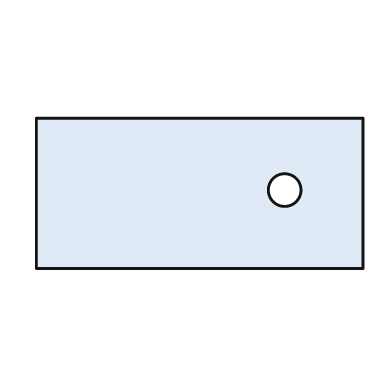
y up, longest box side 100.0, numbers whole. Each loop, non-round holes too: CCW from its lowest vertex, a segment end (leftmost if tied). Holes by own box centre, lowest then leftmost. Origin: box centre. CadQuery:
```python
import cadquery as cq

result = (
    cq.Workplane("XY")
    .moveTo(-50.0, -23.0)
    .lineTo(50.0, -23.0)
    .lineTo(50.0, 23.0)
    .lineTo(-50.0, 23.0)
    .close()
    .moveTo(26.0, 1.0)
    .circle(5.0)
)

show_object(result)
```